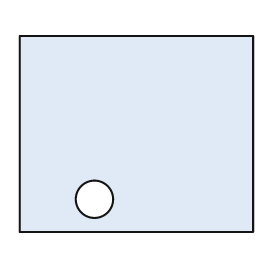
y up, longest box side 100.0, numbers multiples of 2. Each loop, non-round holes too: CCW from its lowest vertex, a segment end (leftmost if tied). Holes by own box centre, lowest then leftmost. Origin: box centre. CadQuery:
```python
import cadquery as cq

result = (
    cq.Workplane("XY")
    .moveTo(-50.0, -42.0)
    .lineTo(50.0, -42.0)
    .lineTo(50.0, 42.0)
    .lineTo(-50.0, 42.0)
    .close()
    .moveTo(-18.0, -28.0)
    .circle(8.0)
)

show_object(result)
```